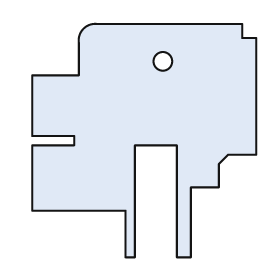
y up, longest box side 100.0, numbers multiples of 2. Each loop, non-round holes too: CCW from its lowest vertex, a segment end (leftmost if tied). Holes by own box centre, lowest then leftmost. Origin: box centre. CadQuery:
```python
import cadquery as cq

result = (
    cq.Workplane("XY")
    .moveTo(-8.0, -50.0)
    .lineTo(-4.0, -50.0)
    .lineTo(-4.0, -2.0)
    .lineTo(14.0, -2.0)
    .lineTo(14.0, -50.0)
    .lineTo(20.0, -50.0)
    .lineTo(20.0, -20.0)
    .lineTo(32.0, -20.0)
    .lineTo(32.0, -10.0)
    .lineTo(36.0, -6.0)
    .lineTo(48.0, -6.0)
    .lineTo(48.0, 44.0)
    .lineTo(42.0, 44.0)
    .lineTo(42.0, 50.0)
    .lineTo(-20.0, 50.0)
    .threePointArc((-26.0, 48.0), (-28.0, 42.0))
    .lineTo(-28.0, 28.0)
    .lineTo(-48.0, 28.0)
    .lineTo(-48.0, 2.0)
    .lineTo(-30.0, 2.0)
    .lineTo(-30.0, -2.0)
    .lineTo(-48.0, -2.0)
    .lineTo(-48.0, -30.0)
    .lineTo(-8.0, -30.0)
    .close()
    .moveTo(8.0, 34.0)
    .circle(4.0)
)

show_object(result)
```